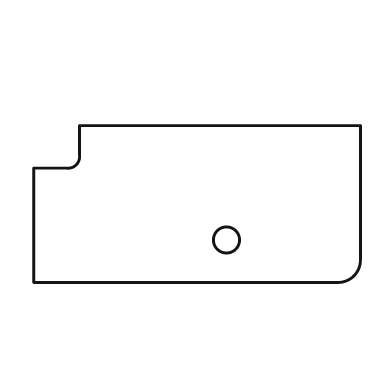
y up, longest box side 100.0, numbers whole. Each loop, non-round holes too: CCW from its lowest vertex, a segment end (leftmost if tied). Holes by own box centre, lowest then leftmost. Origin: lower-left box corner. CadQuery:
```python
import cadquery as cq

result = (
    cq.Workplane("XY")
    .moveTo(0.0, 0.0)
    .lineTo(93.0, 0.0)
    .threePointArc((98.0, 2.0), (100.0, 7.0))
    .lineTo(100.0, 48.0)
    .lineTo(14.0, 48.0)
    .lineTo(14.0, 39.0)
    .threePointArc((13.0, 36.0), (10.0, 35.0))
    .lineTo(0.0, 35.0)
    .close()
    .moveTo(59.0, 13.0)
    .circle(4.0)
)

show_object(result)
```